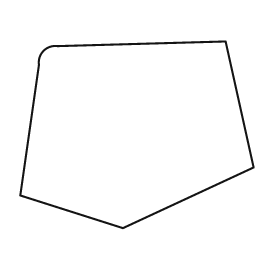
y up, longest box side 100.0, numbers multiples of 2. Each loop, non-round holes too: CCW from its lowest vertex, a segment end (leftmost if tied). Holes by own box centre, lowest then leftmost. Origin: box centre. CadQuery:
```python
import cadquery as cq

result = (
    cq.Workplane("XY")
    .moveTo(-6.0, -40.0)
    .lineTo(50.0, -14.0)
    .lineTo(38.0, 40.0)
    .lineTo(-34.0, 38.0)
    .threePointArc((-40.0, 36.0), (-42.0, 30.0))
    .lineTo(-50.0, -26.0)
    .close()
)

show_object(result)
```